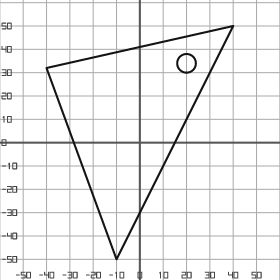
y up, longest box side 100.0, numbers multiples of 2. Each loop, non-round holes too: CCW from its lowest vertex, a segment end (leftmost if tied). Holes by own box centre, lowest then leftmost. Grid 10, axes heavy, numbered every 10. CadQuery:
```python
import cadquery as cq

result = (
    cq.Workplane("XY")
    .moveTo(-10.0, -50.0)
    .lineTo(40.0, 50.0)
    .lineTo(-40.0, 32.0)
    .close()
    .moveTo(20.0, 34.0)
    .circle(4.0)
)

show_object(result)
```